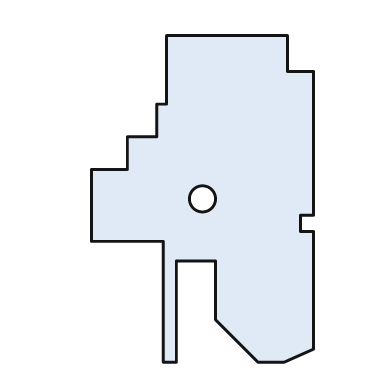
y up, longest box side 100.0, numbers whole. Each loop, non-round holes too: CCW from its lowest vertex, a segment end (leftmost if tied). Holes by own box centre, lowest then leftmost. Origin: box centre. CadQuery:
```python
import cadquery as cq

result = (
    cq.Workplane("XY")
    .moveTo(-12.0, -50.0)
    .lineTo(-8.0, -50.0)
    .lineTo(-8.0, -19.0)
    .lineTo(4.0, -19.0)
    .lineTo(4.0, -37.0)
    .lineTo(17.0, -50.0)
    .lineTo(25.0, -50.0)
    .lineTo(34.0, -46.0)
    .lineTo(34.0, -10.0)
    .lineTo(30.0, -10.0)
    .lineTo(30.0, -5.0)
    .lineTo(34.0, -5.0)
    .lineTo(34.0, 39.0)
    .lineTo(26.0, 39.0)
    .lineTo(26.0, 50.0)
    .lineTo(-11.0, 50.0)
    .lineTo(-11.0, 29.0)
    .lineTo(-14.0, 29.0)
    .lineTo(-14.0, 19.0)
    .lineTo(-23.0, 19.0)
    .lineTo(-23.0, 9.0)
    .lineTo(-34.0, 9.0)
    .lineTo(-34.0, -13.0)
    .lineTo(-12.0, -13.0)
    .close()
    .moveTo(0.0, 0.0)
    .circle(4.0)
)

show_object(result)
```